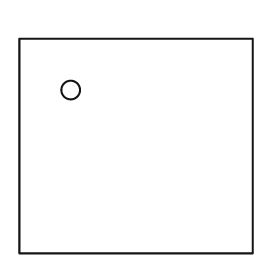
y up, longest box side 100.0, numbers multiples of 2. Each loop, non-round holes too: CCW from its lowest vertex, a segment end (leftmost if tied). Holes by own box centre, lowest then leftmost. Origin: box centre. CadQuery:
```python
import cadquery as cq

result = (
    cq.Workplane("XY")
    .moveTo(-50.0, -46.0)
    .lineTo(50.0, -46.0)
    .lineTo(50.0, 46.0)
    .lineTo(-50.0, 46.0)
    .close()
    .moveTo(-28.0, 24.0)
    .circle(4.0)
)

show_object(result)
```